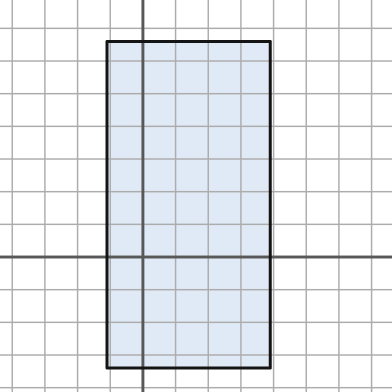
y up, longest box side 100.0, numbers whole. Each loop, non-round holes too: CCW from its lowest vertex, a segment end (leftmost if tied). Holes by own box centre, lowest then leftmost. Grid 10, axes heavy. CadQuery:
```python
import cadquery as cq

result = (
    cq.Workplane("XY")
    .moveTo(-11.0, -34.0)
    .lineTo(39.0, -34.0)
    .lineTo(39.0, 66.0)
    .lineTo(-11.0, 66.0)
    .close()
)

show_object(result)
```